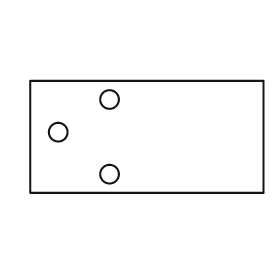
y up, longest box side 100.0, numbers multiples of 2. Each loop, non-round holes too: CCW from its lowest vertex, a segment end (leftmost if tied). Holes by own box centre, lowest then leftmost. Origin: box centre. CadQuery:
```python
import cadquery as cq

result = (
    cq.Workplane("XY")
    .moveTo(-50.0, -24.0)
    .lineTo(50.0, -24.0)
    .lineTo(50.0, 24.0)
    .lineTo(-50.0, 24.0)
    .close()
    .moveTo(-16.0, -16.0)
    .circle(4.0)
    .moveTo(-38.0, 2.0)
    .circle(4.0)
    .moveTo(-16.0, 16.0)
    .circle(4.0)
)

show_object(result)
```